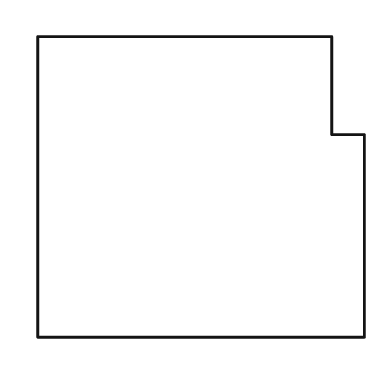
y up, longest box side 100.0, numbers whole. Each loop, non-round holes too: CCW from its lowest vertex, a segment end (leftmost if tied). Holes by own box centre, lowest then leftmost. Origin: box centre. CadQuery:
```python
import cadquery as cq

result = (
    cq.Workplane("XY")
    .moveTo(-50.0, -46.0)
    .lineTo(50.0, -46.0)
    .lineTo(50.0, 16.0)
    .lineTo(40.0, 16.0)
    .lineTo(40.0, 46.0)
    .lineTo(-50.0, 46.0)
    .close()
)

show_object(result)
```